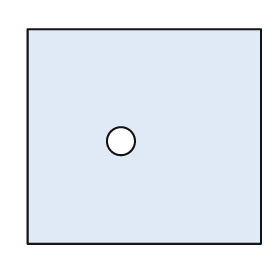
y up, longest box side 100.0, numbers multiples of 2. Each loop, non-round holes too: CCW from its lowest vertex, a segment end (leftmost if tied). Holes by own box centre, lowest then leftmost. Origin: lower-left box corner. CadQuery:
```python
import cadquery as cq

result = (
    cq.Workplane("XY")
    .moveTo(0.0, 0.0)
    .lineTo(100.0, 0.0)
    .lineTo(100.0, 92.0)
    .lineTo(0.0, 92.0)
    .close()
    .moveTo(40.0, 44.0)
    .circle(6.0)
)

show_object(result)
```